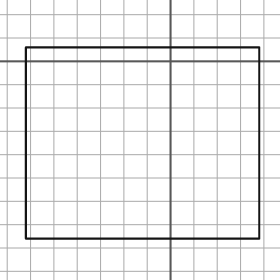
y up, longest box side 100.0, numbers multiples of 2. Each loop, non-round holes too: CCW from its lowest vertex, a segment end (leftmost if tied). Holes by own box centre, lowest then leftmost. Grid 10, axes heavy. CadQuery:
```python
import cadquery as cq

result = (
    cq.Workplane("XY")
    .moveTo(-62.0, -76.0)
    .lineTo(38.0, -76.0)
    .lineTo(38.0, 6.0)
    .lineTo(-62.0, 6.0)
    .close()
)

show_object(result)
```